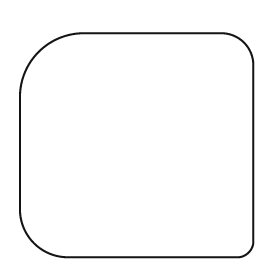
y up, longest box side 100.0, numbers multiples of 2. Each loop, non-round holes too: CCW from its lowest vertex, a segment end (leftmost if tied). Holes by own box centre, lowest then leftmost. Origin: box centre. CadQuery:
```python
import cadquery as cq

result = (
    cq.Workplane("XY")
    .moveTo(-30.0, -48.0)
    .lineTo(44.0, -48.0)
    .threePointArc((48.0, -46.0), (50.0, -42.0))
    .lineTo(50.0, 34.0)
    .threePointArc((46.0, 44.0), (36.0, 48.0))
    .lineTo(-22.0, 48.0)
    .threePointArc((-42.0, 40.0), (-50.0, 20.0))
    .lineTo(-50.0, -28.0)
    .threePointArc((-44.0, -42.0), (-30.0, -48.0))
    .close()
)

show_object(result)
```